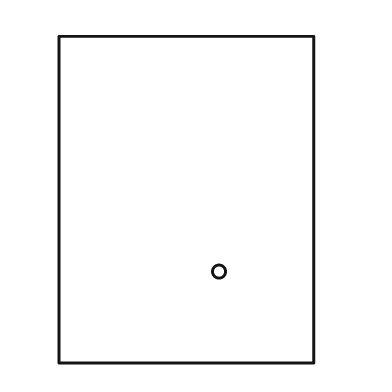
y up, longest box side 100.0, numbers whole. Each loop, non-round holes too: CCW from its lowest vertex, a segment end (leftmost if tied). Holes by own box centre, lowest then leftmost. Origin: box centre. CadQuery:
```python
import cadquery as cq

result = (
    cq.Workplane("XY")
    .moveTo(-39.0, -50.0)
    .lineTo(39.0, -50.0)
    .lineTo(39.0, 50.0)
    .lineTo(-39.0, 50.0)
    .close()
    .moveTo(10.0, -22.0)
    .circle(2.0)
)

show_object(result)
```